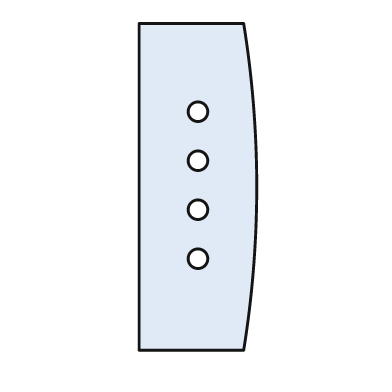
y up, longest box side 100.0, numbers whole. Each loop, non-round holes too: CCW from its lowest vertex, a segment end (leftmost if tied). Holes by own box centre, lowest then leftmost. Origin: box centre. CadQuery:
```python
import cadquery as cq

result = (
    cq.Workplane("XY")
    .moveTo(-18.0, -50.0)
    .lineTo(14.0, -50.0)
    .threePointArc((18.0, 0.0), (14.0, 50.0))
    .lineTo(-18.0, 50.0)
    .close()
    .moveTo(0.0, -22.0)
    .circle(3.0)
    .moveTo(0.0, -7.0)
    .circle(3.0)
    .moveTo(0.0, 8.0)
    .circle(3.0)
    .moveTo(0.0, 23.0)
    .circle(3.0)
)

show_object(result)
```